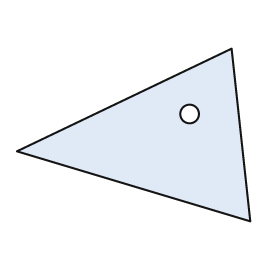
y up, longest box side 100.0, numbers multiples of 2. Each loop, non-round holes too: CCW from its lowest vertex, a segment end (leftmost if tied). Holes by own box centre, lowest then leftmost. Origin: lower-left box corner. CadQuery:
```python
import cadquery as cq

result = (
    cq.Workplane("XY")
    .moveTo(100.0, 0.0)
    .lineTo(92.0, 74.0)
    .lineTo(0.0, 30.0)
    .close()
    .moveTo(74.0, 46.0)
    .circle(4.0)
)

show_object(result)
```